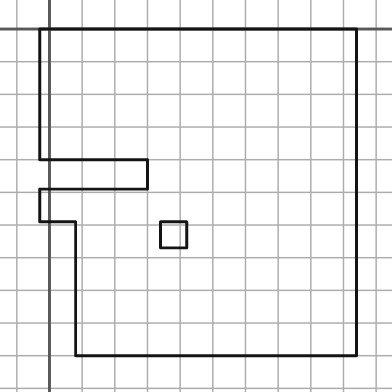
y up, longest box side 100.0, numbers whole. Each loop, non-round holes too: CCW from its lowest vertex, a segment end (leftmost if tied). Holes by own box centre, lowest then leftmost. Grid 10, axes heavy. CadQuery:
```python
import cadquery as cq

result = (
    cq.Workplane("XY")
    .moveTo(8.0, -100.0)
    .lineTo(94.0, -100.0)
    .lineTo(94.0, 0.0)
    .lineTo(-3.0, 0.0)
    .lineTo(-3.0, -40.0)
    .lineTo(30.0, -40.0)
    .lineTo(30.0, -49.0)
    .lineTo(-3.0, -49.0)
    .lineTo(-3.0, -59.0)
    .lineTo(8.0, -59.0)
    .close()
    .moveTo(34.0, -67.0)
    .lineTo(42.0, -67.0)
    .lineTo(42.0, -59.0)
    .lineTo(34.0, -59.0)
    .close()
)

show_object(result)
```